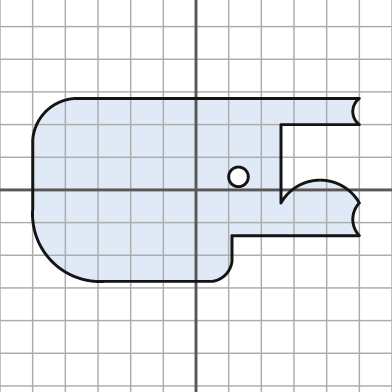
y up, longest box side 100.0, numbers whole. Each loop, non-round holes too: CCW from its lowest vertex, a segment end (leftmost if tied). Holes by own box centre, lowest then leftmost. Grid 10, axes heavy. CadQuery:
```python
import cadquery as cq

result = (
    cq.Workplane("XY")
    .moveTo(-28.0, -28.0)
    .lineTo(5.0, -28.0)
    .threePointArc((9.0, -26.0), (11.0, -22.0))
    .lineTo(11.0, -14.0)
    .lineTo(50.0, -14.0)
    .threePointArc((48.0, -9.0), (50.0, -4.0))
    .threePointArc((38.0, 3.0), (26.0, -4.0))
    .lineTo(26.0, 20.0)
    .lineTo(50.0, 20.0)
    .threePointArc((48.0, 24.0), (50.0, 28.0))
    .lineTo(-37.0, 28.0)
    .threePointArc((-46.0, 24.0), (-50.0, 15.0))
    .lineTo(-50.0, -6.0)
    .threePointArc((-44.0, -22.0), (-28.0, -28.0))
    .close()
    .moveTo(13.0, 4.0)
    .circle(3.0)
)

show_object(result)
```